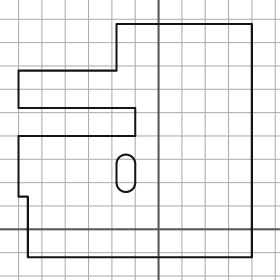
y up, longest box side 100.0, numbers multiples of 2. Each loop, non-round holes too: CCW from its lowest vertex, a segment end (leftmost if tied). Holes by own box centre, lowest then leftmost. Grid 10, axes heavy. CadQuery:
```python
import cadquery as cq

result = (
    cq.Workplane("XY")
    .moveTo(-56.0, -12.0)
    .lineTo(40.0, -12.0)
    .lineTo(40.0, 88.0)
    .lineTo(-18.0, 88.0)
    .lineTo(-18.0, 68.0)
    .lineTo(-60.0, 68.0)
    .lineTo(-60.0, 52.0)
    .lineTo(-10.0, 52.0)
    .lineTo(-10.0, 40.0)
    .lineTo(-60.0, 40.0)
    .lineTo(-60.0, 14.0)
    .lineTo(-56.0, 14.0)
    .close()
    .moveTo(-18.0, 20.0)
    .threePointArc((-14.0, 16.0), (-10.0, 20.0))
    .lineTo(-10.0, 28.0)
    .threePointArc((-14.0, 32.0), (-18.0, 28.0))
    .close()
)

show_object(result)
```